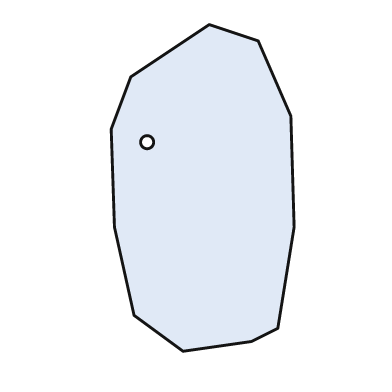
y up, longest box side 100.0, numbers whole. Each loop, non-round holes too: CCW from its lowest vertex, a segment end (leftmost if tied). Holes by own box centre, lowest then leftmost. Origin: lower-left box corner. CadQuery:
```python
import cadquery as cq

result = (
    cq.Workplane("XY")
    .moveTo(22.0, 0.0)
    .lineTo(43.0, 3.0)
    .lineTo(51.0, 7.0)
    .lineTo(56.0, 38.0)
    .lineTo(55.0, 72.0)
    .lineTo(45.0, 95.0)
    .lineTo(30.0, 100.0)
    .lineTo(6.0, 84.0)
    .lineTo(0.0, 68.0)
    .lineTo(1.0, 38.0)
    .lineTo(7.0, 11.0)
    .close()
    .moveTo(11.0, 64.0)
    .circle(2.0)
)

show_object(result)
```